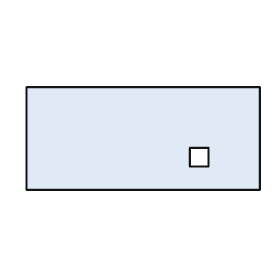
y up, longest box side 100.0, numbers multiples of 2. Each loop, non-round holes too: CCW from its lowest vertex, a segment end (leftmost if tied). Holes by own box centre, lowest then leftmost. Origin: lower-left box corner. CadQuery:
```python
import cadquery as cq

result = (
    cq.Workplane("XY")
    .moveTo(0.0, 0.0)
    .lineTo(100.0, 0.0)
    .lineTo(100.0, 44.0)
    .lineTo(0.0, 44.0)
    .close()
    .moveTo(70.0, 10.0)
    .lineTo(78.0, 10.0)
    .lineTo(78.0, 18.0)
    .lineTo(70.0, 18.0)
    .close()
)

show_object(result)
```